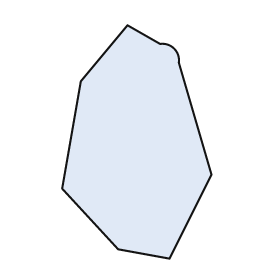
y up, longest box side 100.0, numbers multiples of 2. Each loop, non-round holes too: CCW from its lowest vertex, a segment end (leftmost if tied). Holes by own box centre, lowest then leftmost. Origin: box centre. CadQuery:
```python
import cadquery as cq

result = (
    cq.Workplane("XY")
    .moveTo(14.0, -50.0)
    .lineTo(32.0, -14.0)
    .lineTo(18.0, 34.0)
    .threePointArc((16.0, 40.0), (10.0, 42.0))
    .lineTo(-4.0, 50.0)
    .lineTo(-24.0, 26.0)
    .lineTo(-32.0, -20.0)
    .lineTo(-8.0, -46.0)
    .close()
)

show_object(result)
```